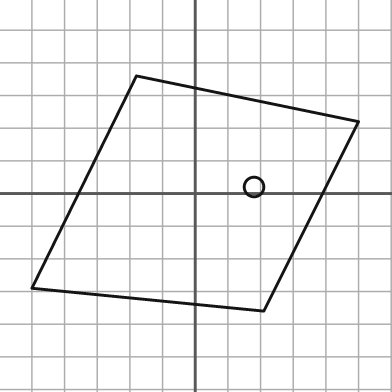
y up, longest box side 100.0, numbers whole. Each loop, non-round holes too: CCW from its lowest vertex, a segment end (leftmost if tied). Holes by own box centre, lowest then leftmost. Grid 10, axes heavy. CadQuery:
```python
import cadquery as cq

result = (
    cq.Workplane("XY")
    .moveTo(21.0, -36.0)
    .lineTo(50.0, 22.0)
    .lineTo(-18.0, 36.0)
    .lineTo(-50.0, -29.0)
    .close()
    .moveTo(18.0, 2.0)
    .circle(3.0)
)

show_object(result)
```